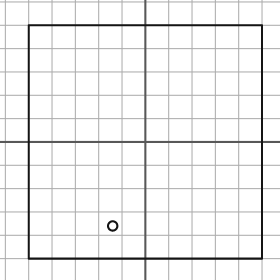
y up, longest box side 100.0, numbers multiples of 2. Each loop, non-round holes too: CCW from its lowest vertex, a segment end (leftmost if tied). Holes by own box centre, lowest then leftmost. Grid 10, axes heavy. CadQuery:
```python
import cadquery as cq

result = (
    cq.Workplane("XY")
    .moveTo(-50.0, -50.0)
    .lineTo(50.0, -50.0)
    .lineTo(50.0, 50.0)
    .lineTo(-50.0, 50.0)
    .close()
    .moveTo(-14.0, -36.0)
    .circle(2.0)
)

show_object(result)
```